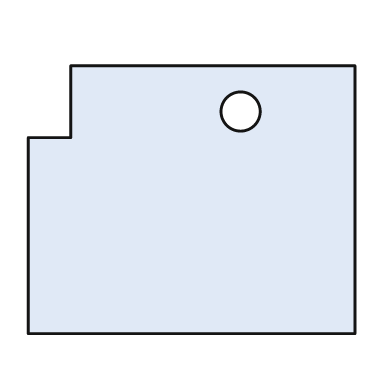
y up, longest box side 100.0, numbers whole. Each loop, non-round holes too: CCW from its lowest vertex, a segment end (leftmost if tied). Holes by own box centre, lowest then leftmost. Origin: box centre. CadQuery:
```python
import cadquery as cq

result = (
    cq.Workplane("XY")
    .moveTo(-50.0, -41.0)
    .lineTo(50.0, -41.0)
    .lineTo(50.0, 41.0)
    .lineTo(-37.0, 41.0)
    .lineTo(-37.0, 19.0)
    .lineTo(-50.0, 19.0)
    .close()
    .moveTo(15.0, 27.0)
    .circle(6.0)
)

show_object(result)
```